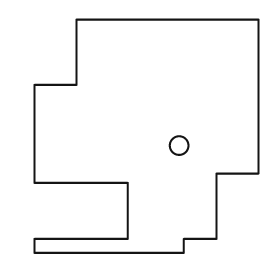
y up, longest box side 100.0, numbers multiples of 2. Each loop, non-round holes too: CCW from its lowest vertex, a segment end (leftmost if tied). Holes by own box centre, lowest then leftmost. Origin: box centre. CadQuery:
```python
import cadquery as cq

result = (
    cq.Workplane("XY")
    .moveTo(-48.0, -50.0)
    .lineTo(16.0, -50.0)
    .lineTo(16.0, -44.0)
    .lineTo(30.0, -44.0)
    .lineTo(30.0, -16.0)
    .lineTo(48.0, -16.0)
    .lineTo(48.0, 50.0)
    .lineTo(-30.0, 50.0)
    .lineTo(-30.0, 22.0)
    .lineTo(-48.0, 22.0)
    .lineTo(-48.0, -20.0)
    .lineTo(-8.0, -20.0)
    .lineTo(-8.0, -44.0)
    .lineTo(-48.0, -44.0)
    .close()
    .moveTo(14.0, -4.0)
    .circle(4.0)
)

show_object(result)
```